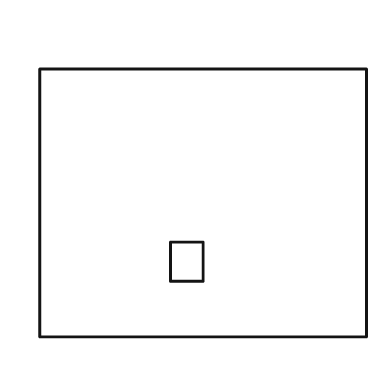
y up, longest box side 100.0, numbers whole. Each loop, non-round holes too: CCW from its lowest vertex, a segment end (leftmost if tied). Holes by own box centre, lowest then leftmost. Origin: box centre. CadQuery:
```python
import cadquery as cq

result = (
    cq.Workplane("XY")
    .moveTo(-50.0, -41.0)
    .lineTo(50.0, -41.0)
    .lineTo(50.0, 41.0)
    .lineTo(-50.0, 41.0)
    .close()
    .moveTo(-10.0, -24.0)
    .lineTo(0.0, -24.0)
    .lineTo(0.0, -12.0)
    .lineTo(-10.0, -12.0)
    .close()
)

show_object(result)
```